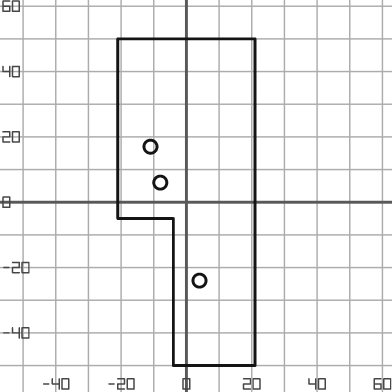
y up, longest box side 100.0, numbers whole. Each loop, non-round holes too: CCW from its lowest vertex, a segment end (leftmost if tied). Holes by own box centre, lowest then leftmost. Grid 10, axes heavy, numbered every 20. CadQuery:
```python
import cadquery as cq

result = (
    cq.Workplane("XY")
    .moveTo(-4.0, -50.0)
    .lineTo(21.0, -50.0)
    .lineTo(21.0, 50.0)
    .lineTo(-21.0, 50.0)
    .lineTo(-21.0, -5.0)
    .lineTo(-4.0, -5.0)
    .close()
    .moveTo(4.0, -24.0)
    .circle(2.0)
    .moveTo(-8.0, 6.0)
    .circle(2.0)
    .moveTo(-11.0, 17.0)
    .circle(2.0)
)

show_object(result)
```